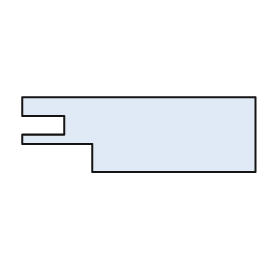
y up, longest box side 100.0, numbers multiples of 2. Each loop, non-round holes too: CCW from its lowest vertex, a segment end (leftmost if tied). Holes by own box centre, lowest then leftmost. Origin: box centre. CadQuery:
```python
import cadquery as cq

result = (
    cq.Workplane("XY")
    .moveTo(-20.0, -16.0)
    .lineTo(50.0, -16.0)
    .lineTo(50.0, 16.0)
    .lineTo(-50.0, 16.0)
    .lineTo(-50.0, 8.0)
    .lineTo(-32.0, 8.0)
    .lineTo(-32.0, 0.0)
    .lineTo(-50.0, 0.0)
    .lineTo(-50.0, -4.0)
    .lineTo(-20.0, -4.0)
    .close()
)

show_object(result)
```